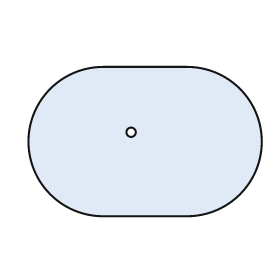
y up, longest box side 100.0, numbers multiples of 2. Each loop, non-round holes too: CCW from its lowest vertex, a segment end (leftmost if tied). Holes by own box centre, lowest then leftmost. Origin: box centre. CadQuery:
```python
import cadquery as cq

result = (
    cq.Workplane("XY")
    .moveTo(-18.0, -32.0)
    .lineTo(18.0, -32.0)
    .threePointArc((50.0, 0.0), (18.0, 32.0))
    .lineTo(-18.0, 32.0)
    .threePointArc((-50.0, 0.0), (-18.0, -32.0))
    .close()
    .moveTo(-6.0, 4.0)
    .circle(2.0)
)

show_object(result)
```